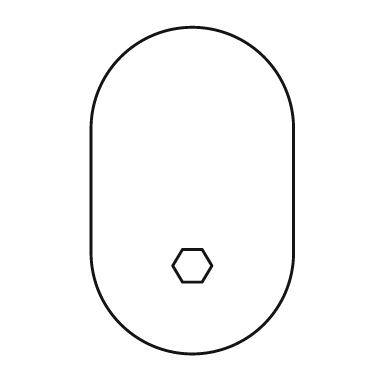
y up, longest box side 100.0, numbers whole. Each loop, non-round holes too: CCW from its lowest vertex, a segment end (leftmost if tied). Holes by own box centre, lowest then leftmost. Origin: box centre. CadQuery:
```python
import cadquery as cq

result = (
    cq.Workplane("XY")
    .moveTo(-31.0, -19.0)
    .threePointArc((0.0, -50.0), (31.0, -19.0))
    .lineTo(31.0, 19.0)
    .threePointArc((0.0, 50.0), (-31.0, 19.0))
    .close()
    .moveTo(-3.0, -28.0)
    .lineTo(3.0, -28.0)
    .lineTo(6.0, -23.0)
    .lineTo(3.0, -18.0)
    .lineTo(-3.0, -18.0)
    .lineTo(-6.0, -23.0)
    .close()
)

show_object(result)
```